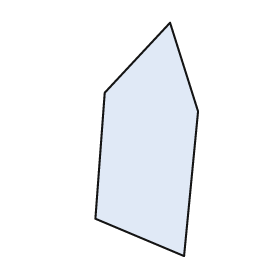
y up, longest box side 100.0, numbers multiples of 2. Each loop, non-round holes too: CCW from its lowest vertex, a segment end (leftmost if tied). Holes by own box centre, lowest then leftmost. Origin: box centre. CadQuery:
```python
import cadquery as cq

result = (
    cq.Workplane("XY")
    .moveTo(16.0, -50.0)
    .lineTo(22.0, 12.0)
    .lineTo(10.0, 50.0)
    .lineTo(-18.0, 20.0)
    .lineTo(-22.0, -34.0)
    .close()
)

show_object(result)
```